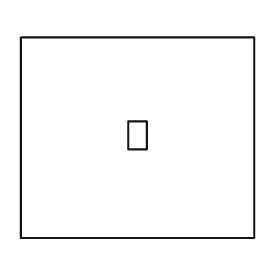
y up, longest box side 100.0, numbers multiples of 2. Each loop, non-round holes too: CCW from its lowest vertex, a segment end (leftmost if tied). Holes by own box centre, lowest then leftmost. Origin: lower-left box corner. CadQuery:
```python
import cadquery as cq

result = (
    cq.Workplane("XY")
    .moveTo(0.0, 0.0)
    .lineTo(100.0, 0.0)
    .lineTo(100.0, 86.0)
    .lineTo(0.0, 86.0)
    .close()
    .moveTo(46.0, 38.0)
    .lineTo(54.0, 38.0)
    .lineTo(54.0, 50.0)
    .lineTo(46.0, 50.0)
    .close()
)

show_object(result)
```